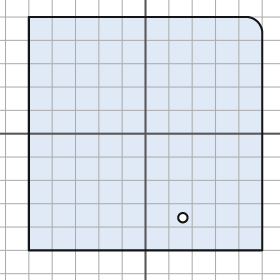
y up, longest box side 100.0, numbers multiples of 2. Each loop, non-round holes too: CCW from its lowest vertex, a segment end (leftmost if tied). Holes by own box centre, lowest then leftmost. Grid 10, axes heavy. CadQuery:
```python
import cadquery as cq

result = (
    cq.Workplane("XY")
    .moveTo(-50.0, -50.0)
    .lineTo(50.0, -50.0)
    .lineTo(50.0, 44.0)
    .threePointArc((48.0, 48.0), (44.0, 50.0))
    .lineTo(-50.0, 50.0)
    .close()
    .moveTo(16.0, -36.0)
    .circle(2.0)
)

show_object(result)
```